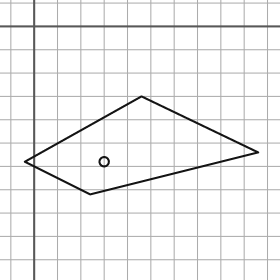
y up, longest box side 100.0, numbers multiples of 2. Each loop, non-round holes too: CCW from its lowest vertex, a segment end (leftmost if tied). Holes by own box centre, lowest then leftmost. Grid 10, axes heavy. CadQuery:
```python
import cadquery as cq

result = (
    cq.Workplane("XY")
    .moveTo(24.0, -72.0)
    .lineTo(96.0, -54.0)
    .lineTo(46.0, -30.0)
    .lineTo(-4.0, -58.0)
    .close()
    .moveTo(30.0, -58.0)
    .circle(2.0)
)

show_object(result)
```